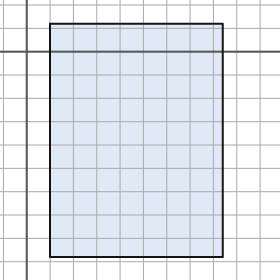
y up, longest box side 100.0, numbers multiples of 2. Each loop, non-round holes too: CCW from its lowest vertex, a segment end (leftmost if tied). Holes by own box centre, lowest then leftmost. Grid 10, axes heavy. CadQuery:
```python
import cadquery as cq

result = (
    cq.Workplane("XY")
    .moveTo(10.0, -88.0)
    .lineTo(84.0, -88.0)
    .lineTo(84.0, 12.0)
    .lineTo(10.0, 12.0)
    .close()
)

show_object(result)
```